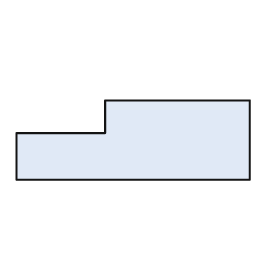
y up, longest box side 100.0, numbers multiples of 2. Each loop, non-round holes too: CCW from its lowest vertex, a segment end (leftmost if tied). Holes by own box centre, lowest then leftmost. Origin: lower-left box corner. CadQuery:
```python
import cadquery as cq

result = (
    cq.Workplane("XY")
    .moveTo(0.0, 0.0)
    .lineTo(100.0, 0.0)
    .lineTo(100.0, 34.0)
    .lineTo(38.0, 34.0)
    .lineTo(38.0, 20.0)
    .lineTo(0.0, 20.0)
    .close()
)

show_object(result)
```